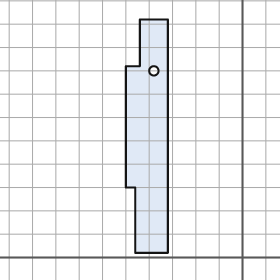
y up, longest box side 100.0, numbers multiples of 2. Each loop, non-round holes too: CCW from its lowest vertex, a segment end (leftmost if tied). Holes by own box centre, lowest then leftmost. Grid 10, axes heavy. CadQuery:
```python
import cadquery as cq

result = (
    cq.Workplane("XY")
    .moveTo(-46.0, 2.0)
    .lineTo(-32.0, 2.0)
    .lineTo(-32.0, 102.0)
    .lineTo(-44.0, 102.0)
    .lineTo(-44.0, 82.0)
    .lineTo(-50.0, 82.0)
    .lineTo(-50.0, 30.0)
    .lineTo(-46.0, 30.0)
    .close()
    .moveTo(-38.0, 80.0)
    .circle(2.0)
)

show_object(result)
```